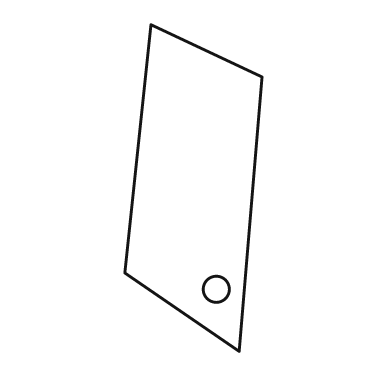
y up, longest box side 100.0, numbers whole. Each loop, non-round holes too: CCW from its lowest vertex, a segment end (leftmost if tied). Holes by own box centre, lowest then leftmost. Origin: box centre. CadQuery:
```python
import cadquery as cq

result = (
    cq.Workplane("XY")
    .moveTo(14.0, -50.0)
    .lineTo(21.0, 34.0)
    .lineTo(-13.0, 50.0)
    .lineTo(-21.0, -26.0)
    .close()
    .moveTo(7.0, -31.0)
    .circle(4.0)
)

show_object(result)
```